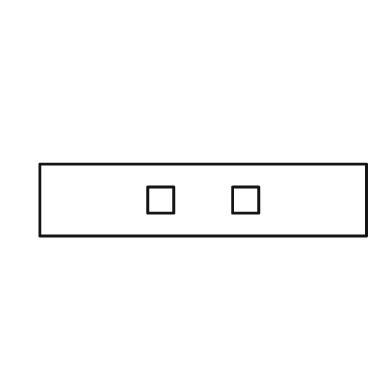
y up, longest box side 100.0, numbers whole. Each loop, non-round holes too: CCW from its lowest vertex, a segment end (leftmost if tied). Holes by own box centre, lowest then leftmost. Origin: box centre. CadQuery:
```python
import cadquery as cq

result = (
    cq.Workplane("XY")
    .moveTo(-50.0, -11.0)
    .lineTo(50.0, -11.0)
    .lineTo(50.0, 11.0)
    .lineTo(-50.0, 11.0)
    .close()
    .moveTo(-17.0, -4.0)
    .lineTo(-9.0, -4.0)
    .lineTo(-9.0, 4.0)
    .lineTo(-17.0, 4.0)
    .close()
    .moveTo(9.0, -4.0)
    .lineTo(17.0, -4.0)
    .lineTo(17.0, 4.0)
    .lineTo(9.0, 4.0)
    .close()
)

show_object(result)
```